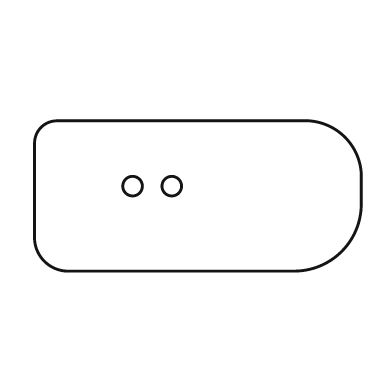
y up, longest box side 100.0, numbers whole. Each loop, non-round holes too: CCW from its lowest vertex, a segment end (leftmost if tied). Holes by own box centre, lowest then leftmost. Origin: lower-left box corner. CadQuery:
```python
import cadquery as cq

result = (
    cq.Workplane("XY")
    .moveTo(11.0, 0.0)
    .lineTo(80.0, 0.0)
    .threePointArc((94.0, 6.0), (100.0, 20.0))
    .lineTo(100.0, 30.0)
    .threePointArc((95.0, 41.0), (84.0, 46.0))
    .lineTo(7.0, 46.0)
    .threePointArc((2.0, 44.0), (0.0, 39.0))
    .lineTo(0.0, 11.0)
    .threePointArc((3.0, 3.0), (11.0, 0.0))
    .close()
    .moveTo(30.0, 26.0)
    .circle(3.0)
    .moveTo(42.0, 26.0)
    .circle(3.0)
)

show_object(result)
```